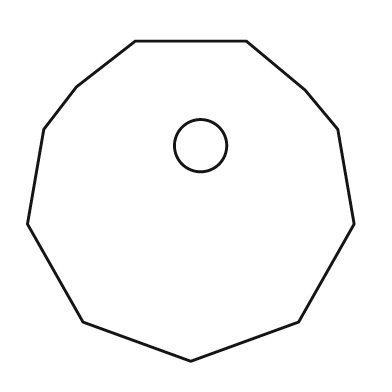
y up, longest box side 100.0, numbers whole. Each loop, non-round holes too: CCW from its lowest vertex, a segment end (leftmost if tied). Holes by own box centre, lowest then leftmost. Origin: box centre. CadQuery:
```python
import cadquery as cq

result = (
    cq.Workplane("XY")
    .moveTo(0.0, -49.0)
    .lineTo(33.0, -37.0)
    .lineTo(50.0, -7.0)
    .lineTo(45.0, 22.0)
    .lineTo(35.0, 34.0)
    .lineTo(17.0, 49.0)
    .lineTo(-17.0, 49.0)
    .lineTo(-35.0, 35.0)
    .lineTo(-45.0, 22.0)
    .lineTo(-50.0, -7.0)
    .lineTo(-33.0, -37.0)
    .close()
    .moveTo(3.0, 17.0)
    .circle(8.0)
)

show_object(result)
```